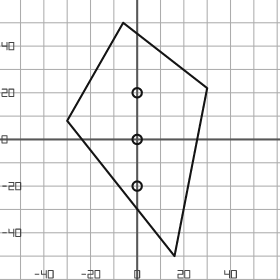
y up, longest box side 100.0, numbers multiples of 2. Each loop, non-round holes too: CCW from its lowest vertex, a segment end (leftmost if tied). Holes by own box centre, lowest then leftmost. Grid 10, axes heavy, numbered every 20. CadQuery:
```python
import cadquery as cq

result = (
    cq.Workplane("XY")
    .moveTo(16.0, -50.0)
    .lineTo(30.0, 22.0)
    .lineTo(-6.0, 50.0)
    .lineTo(-30.0, 8.0)
    .close()
    .moveTo(0.0, -20.0)
    .circle(2.0)
    .moveTo(0.0, 0.0)
    .circle(2.0)
    .moveTo(0.0, 20.0)
    .circle(2.0)
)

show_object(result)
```